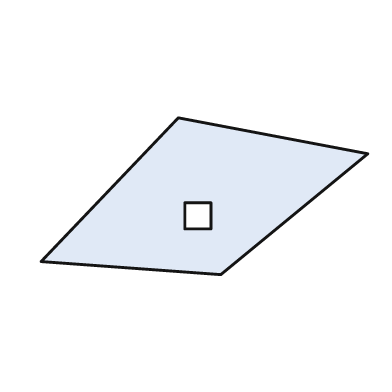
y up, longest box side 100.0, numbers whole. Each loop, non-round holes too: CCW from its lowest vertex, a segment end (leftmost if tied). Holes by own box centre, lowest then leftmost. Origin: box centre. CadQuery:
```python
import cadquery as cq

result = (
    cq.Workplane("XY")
    .moveTo(5.0, -24.0)
    .lineTo(50.0, 13.0)
    .lineTo(-8.0, 24.0)
    .lineTo(-50.0, -20.0)
    .close()
    .moveTo(-6.0, -10.0)
    .lineTo(2.0, -10.0)
    .lineTo(2.0, -2.0)
    .lineTo(-6.0, -2.0)
    .close()
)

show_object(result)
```